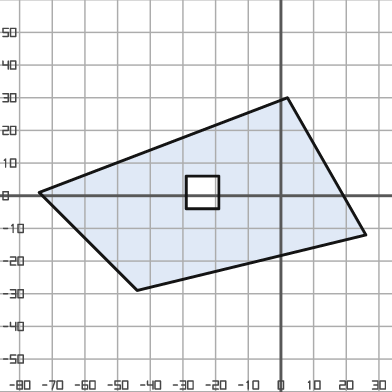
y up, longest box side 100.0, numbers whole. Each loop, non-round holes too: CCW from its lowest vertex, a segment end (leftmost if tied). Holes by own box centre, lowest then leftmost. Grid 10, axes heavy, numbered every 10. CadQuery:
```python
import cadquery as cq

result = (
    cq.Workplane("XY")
    .moveTo(-44.0, -29.0)
    .lineTo(26.0, -12.0)
    .lineTo(2.0, 30.0)
    .lineTo(-74.0, 1.0)
    .close()
    .moveTo(-29.0, -4.0)
    .lineTo(-19.0, -4.0)
    .lineTo(-19.0, 6.0)
    .lineTo(-29.0, 6.0)
    .close()
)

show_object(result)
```